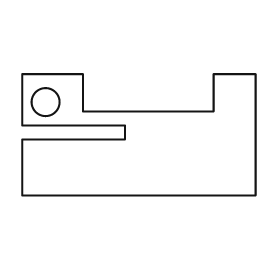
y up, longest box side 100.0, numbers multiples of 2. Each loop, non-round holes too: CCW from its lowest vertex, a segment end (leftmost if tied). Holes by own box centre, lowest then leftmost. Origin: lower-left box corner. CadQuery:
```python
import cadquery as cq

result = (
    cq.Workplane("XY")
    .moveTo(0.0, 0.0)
    .lineTo(100.0, 0.0)
    .lineTo(100.0, 52.0)
    .lineTo(82.0, 52.0)
    .lineTo(82.0, 36.0)
    .lineTo(26.0, 36.0)
    .lineTo(26.0, 52.0)
    .lineTo(0.0, 52.0)
    .lineTo(0.0, 30.0)
    .lineTo(44.0, 30.0)
    .lineTo(44.0, 24.0)
    .lineTo(0.0, 24.0)
    .close()
    .moveTo(10.0, 40.0)
    .circle(6.0)
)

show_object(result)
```